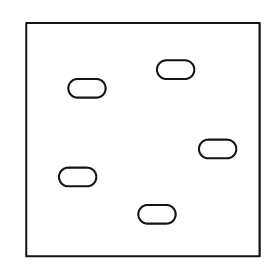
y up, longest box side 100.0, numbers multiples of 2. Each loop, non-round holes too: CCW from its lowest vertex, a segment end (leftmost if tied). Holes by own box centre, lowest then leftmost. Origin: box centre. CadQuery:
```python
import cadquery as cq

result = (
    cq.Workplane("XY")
    .moveTo(-50.0, -50.0)
    .lineTo(50.0, -50.0)
    .lineTo(50.0, 50.0)
    .lineTo(-50.0, 50.0)
    .close()
    .moveTo(2.0, -36.0)
    .lineTo(10.0, -36.0)
    .threePointArc((14.0, -32.0), (10.0, -28.0))
    .lineTo(2.0, -28.0)
    .threePointArc((-2.0, -32.0), (2.0, -36.0))
    .close()
    .moveTo(-32.0, -20.0)
    .lineTo(-24.0, -20.0)
    .threePointArc((-20.0, -16.0), (-24.0, -12.0))
    .lineTo(-32.0, -12.0)
    .threePointArc((-36.0, -16.0), (-32.0, -20.0))
    .close()
    .moveTo(28.0, -8.0)
    .lineTo(36.0, -8.0)
    .threePointArc((40.0, -4.0), (36.0, 0.0))
    .lineTo(28.0, 0.0)
    .threePointArc((24.0, -4.0), (28.0, -8.0))
    .close()
    .moveTo(-28.0, 18.0)
    .lineTo(-20.0, 18.0)
    .threePointArc((-16.0, 22.0), (-20.0, 26.0))
    .lineTo(-28.0, 26.0)
    .threePointArc((-32.0, 22.0), (-28.0, 18.0))
    .close()
    .moveTo(10.0, 26.0)
    .lineTo(18.0, 26.0)
    .threePointArc((22.0, 30.0), (18.0, 34.0))
    .lineTo(10.0, 34.0)
    .threePointArc((6.0, 30.0), (10.0, 26.0))
    .close()
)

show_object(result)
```